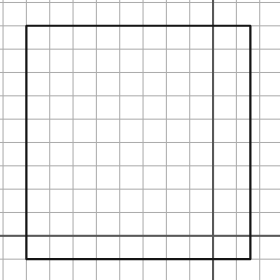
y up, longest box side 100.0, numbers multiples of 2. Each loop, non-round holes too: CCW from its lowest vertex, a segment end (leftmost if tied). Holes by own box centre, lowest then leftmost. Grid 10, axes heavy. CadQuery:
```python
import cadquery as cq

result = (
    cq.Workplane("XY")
    .moveTo(-80.0, -10.0)
    .lineTo(16.0, -10.0)
    .lineTo(16.0, 90.0)
    .lineTo(-80.0, 90.0)
    .close()
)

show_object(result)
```